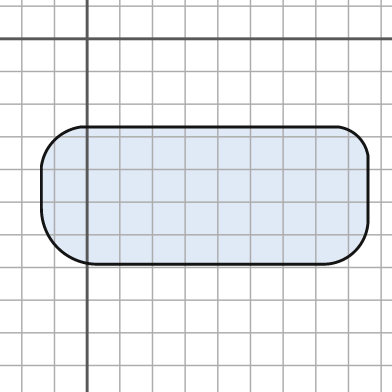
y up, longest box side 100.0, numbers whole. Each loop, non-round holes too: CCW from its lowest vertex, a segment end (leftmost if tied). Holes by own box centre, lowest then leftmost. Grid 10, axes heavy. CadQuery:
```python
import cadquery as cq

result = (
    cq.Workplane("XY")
    .moveTo(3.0, -69.0)
    .lineTo(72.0, -69.0)
    .threePointArc((82.0, -65.0), (86.0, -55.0))
    .lineTo(86.0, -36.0)
    .threePointArc((83.0, -30.0), (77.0, -27.0))
    .lineTo(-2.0, -27.0)
    .threePointArc((-10.0, -31.0), (-14.0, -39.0))
    .lineTo(-14.0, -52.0)
    .threePointArc((-9.0, -64.0), (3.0, -69.0))
    .close()
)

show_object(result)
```